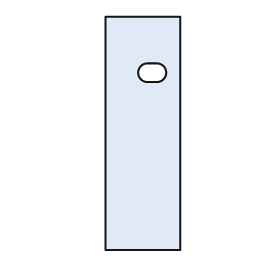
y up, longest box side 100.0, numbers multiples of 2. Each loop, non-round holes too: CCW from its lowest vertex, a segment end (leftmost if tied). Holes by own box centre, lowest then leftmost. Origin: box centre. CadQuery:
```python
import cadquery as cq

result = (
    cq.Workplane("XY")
    .moveTo(-16.0, -50.0)
    .lineTo(16.0, -50.0)
    .lineTo(16.0, 50.0)
    .lineTo(-16.0, 50.0)
    .close()
    .moveTo(2.0, 22.0)
    .lineTo(6.0, 22.0)
    .threePointArc((10.0, 26.0), (6.0, 30.0))
    .lineTo(2.0, 30.0)
    .threePointArc((-2.0, 26.0), (2.0, 22.0))
    .close()
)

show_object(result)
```